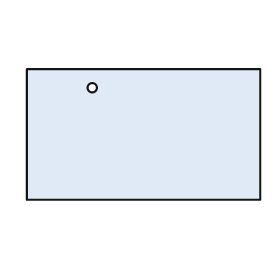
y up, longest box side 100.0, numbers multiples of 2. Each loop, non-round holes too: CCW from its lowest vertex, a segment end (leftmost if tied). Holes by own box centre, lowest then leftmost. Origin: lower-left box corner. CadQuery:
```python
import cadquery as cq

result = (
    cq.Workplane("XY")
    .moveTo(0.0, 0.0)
    .lineTo(100.0, 0.0)
    .lineTo(100.0, 56.0)
    .lineTo(0.0, 56.0)
    .close()
    .moveTo(28.0, 48.0)
    .circle(2.0)
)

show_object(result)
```